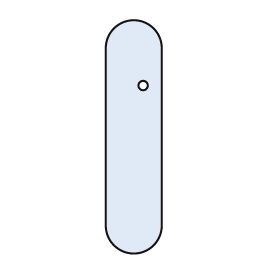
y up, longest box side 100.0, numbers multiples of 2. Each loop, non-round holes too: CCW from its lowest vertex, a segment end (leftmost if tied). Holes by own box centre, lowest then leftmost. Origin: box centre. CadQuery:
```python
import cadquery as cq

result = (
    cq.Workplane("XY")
    .moveTo(-12.0, -38.0)
    .threePointArc((0.0, -50.0), (12.0, -38.0))
    .lineTo(12.0, 38.0)
    .threePointArc((0.0, 50.0), (-12.0, 38.0))
    .close()
    .moveTo(4.0, 22.0)
    .circle(2.0)
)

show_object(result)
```